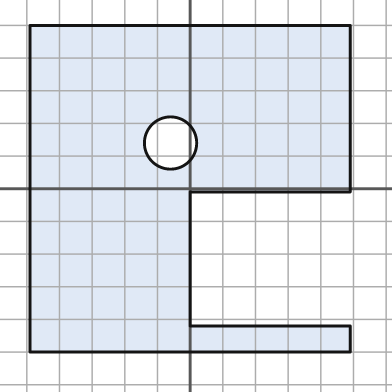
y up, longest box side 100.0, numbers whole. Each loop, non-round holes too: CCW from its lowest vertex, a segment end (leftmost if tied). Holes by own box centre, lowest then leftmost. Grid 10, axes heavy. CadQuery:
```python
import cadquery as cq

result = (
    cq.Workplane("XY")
    .moveTo(-49.0, -50.0)
    .lineTo(49.0, -50.0)
    .lineTo(49.0, -42.0)
    .lineTo(0.0, -42.0)
    .lineTo(0.0, -1.0)
    .lineTo(49.0, -1.0)
    .lineTo(49.0, 50.0)
    .lineTo(-49.0, 50.0)
    .close()
    .moveTo(-6.0, 14.0)
    .circle(8.0)
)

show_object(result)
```